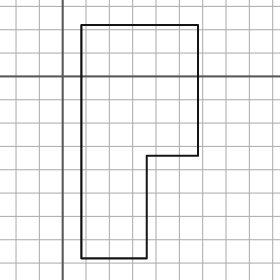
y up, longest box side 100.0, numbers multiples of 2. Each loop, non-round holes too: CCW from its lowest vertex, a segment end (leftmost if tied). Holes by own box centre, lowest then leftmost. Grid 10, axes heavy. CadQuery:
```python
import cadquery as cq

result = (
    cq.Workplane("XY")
    .moveTo(8.0, -78.0)
    .lineTo(36.0, -78.0)
    .lineTo(36.0, -34.0)
    .lineTo(58.0, -34.0)
    .lineTo(58.0, 22.0)
    .lineTo(8.0, 22.0)
    .close()
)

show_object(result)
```